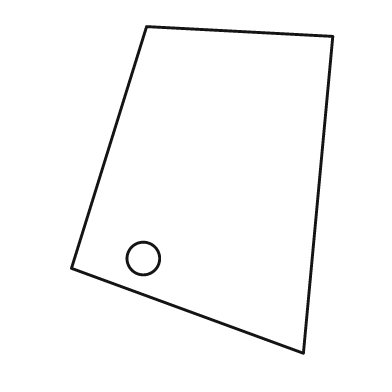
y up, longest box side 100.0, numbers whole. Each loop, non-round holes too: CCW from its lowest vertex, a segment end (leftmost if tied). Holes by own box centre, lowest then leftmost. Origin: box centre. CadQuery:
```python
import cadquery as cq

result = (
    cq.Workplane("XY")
    .moveTo(31.0, -50.0)
    .lineTo(40.0, 47.0)
    .lineTo(-17.0, 50.0)
    .lineTo(-40.0, -24.0)
    .close()
    .moveTo(-18.0, -21.0)
    .circle(5.0)
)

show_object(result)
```